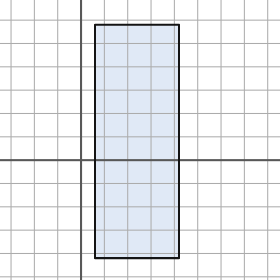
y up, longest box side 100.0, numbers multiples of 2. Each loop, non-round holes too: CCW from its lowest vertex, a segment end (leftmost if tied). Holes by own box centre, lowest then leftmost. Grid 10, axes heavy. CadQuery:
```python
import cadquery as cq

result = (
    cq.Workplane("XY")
    .moveTo(6.0, -42.0)
    .lineTo(42.0, -42.0)
    .lineTo(42.0, 58.0)
    .lineTo(6.0, 58.0)
    .close()
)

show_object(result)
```